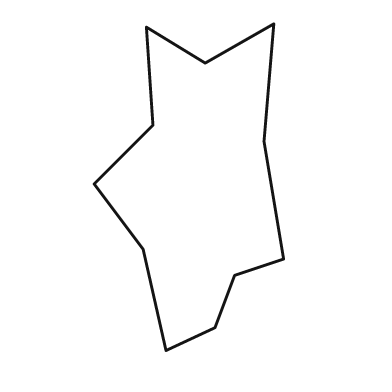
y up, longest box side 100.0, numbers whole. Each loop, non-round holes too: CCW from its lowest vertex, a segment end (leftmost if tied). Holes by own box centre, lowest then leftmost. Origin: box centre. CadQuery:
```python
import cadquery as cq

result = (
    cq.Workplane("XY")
    .moveTo(-7.0, -50.0)
    .lineTo(8.0, -43.0)
    .lineTo(14.0, -27.0)
    .lineTo(29.0, -22.0)
    .lineTo(23.0, 14.0)
    .lineTo(26.0, 50.0)
    .lineTo(5.0, 38.0)
    .lineTo(-13.0, 49.0)
    .lineTo(-11.0, 19.0)
    .lineTo(-29.0, 1.0)
    .lineTo(-14.0, -19.0)
    .close()
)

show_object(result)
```